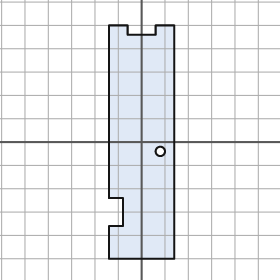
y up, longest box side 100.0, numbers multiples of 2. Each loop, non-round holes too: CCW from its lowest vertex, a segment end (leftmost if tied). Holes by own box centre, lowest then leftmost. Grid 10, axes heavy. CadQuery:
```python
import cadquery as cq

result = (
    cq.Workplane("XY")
    .moveTo(-14.0, -50.0)
    .lineTo(14.0, -50.0)
    .lineTo(14.0, 50.0)
    .lineTo(6.0, 50.0)
    .lineTo(6.0, 46.0)
    .lineTo(-6.0, 46.0)
    .lineTo(-6.0, 50.0)
    .lineTo(-14.0, 50.0)
    .lineTo(-14.0, -24.0)
    .lineTo(-8.0, -24.0)
    .lineTo(-8.0, -36.0)
    .lineTo(-14.0, -36.0)
    .close()
    .moveTo(8.0, -4.0)
    .circle(2.0)
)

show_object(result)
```